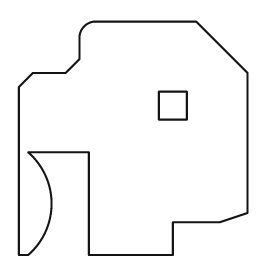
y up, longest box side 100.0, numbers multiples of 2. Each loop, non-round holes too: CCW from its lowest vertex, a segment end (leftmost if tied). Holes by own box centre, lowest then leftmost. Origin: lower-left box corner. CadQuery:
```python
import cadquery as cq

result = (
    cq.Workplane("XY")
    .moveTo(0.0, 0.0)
    .lineTo(4.0, 0.0)
    .threePointArc((14.0, 22.0), (4.0, 44.0))
    .lineTo(30.0, 44.0)
    .lineTo(30.0, 0.0)
    .lineTo(66.0, 0.0)
    .lineTo(66.0, 14.0)
    .lineTo(86.0, 14.0)
    .lineTo(98.0, 18.0)
    .lineTo(98.0, 78.0)
    .lineTo(76.0, 100.0)
    .lineTo(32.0, 100.0)
    .threePointArc((28.0, 98.0), (26.0, 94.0))
    .lineTo(26.0, 84.0)
    .lineTo(20.0, 78.0)
    .lineTo(6.0, 78.0)
    .lineTo(0.0, 72.0)
    .close()
    .moveTo(60.0, 58.0)
    .lineTo(72.0, 58.0)
    .lineTo(72.0, 70.0)
    .lineTo(60.0, 70.0)
    .close()
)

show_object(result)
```